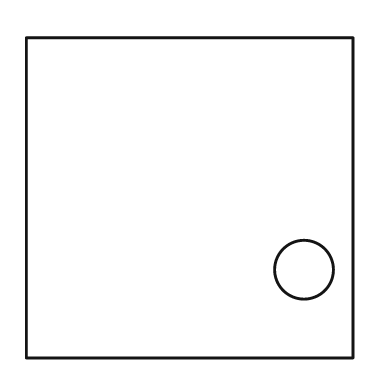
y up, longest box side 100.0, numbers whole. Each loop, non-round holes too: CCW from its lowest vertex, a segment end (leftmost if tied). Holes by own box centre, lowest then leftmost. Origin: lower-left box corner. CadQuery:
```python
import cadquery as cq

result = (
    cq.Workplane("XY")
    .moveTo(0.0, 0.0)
    .lineTo(100.0, 0.0)
    .lineTo(100.0, 98.0)
    .lineTo(0.0, 98.0)
    .close()
    .moveTo(85.0, 27.0)
    .circle(9.0)
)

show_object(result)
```